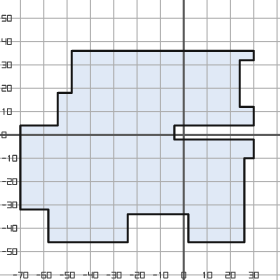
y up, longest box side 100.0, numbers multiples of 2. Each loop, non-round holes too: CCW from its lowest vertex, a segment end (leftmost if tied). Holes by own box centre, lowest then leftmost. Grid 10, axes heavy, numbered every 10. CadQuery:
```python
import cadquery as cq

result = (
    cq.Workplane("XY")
    .moveTo(-58.0, -46.0)
    .lineTo(-24.0, -46.0)
    .lineTo(-24.0, -34.0)
    .lineTo(2.0, -34.0)
    .lineTo(2.0, -46.0)
    .lineTo(26.0, -46.0)
    .lineTo(26.0, -10.0)
    .lineTo(30.0, -10.0)
    .lineTo(30.0, -2.0)
    .lineTo(-4.0, -2.0)
    .lineTo(-4.0, 4.0)
    .lineTo(30.0, 4.0)
    .lineTo(30.0, 12.0)
    .lineTo(24.0, 12.0)
    .lineTo(24.0, 32.0)
    .lineTo(30.0, 32.0)
    .lineTo(30.0, 36.0)
    .lineTo(-48.0, 36.0)
    .lineTo(-48.0, 18.0)
    .lineTo(-54.0, 18.0)
    .lineTo(-54.0, 4.0)
    .lineTo(-70.0, 4.0)
    .lineTo(-70.0, -32.0)
    .lineTo(-58.0, -32.0)
    .close()
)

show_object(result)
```